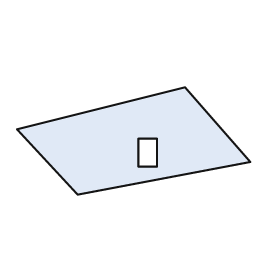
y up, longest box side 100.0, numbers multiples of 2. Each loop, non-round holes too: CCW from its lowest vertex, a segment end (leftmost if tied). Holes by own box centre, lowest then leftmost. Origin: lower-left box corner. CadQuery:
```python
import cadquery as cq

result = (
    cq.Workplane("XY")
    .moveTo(26.0, 0.0)
    .lineTo(100.0, 14.0)
    .lineTo(72.0, 46.0)
    .lineTo(0.0, 28.0)
    .close()
    .moveTo(52.0, 12.0)
    .lineTo(60.0, 12.0)
    .lineTo(60.0, 24.0)
    .lineTo(52.0, 24.0)
    .close()
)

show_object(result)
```